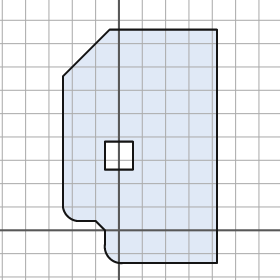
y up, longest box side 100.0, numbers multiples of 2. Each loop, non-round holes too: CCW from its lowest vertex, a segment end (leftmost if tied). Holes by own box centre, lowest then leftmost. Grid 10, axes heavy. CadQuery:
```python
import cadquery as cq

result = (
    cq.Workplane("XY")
    .moveTo(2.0, -14.0)
    .lineTo(42.0, -14.0)
    .lineTo(42.0, 86.0)
    .lineTo(-4.0, 86.0)
    .lineTo(-24.0, 66.0)
    .lineTo(-24.0, 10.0)
    .threePointArc((-22.0, 6.0), (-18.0, 4.0))
    .lineTo(-10.0, 4.0)
    .lineTo(-6.0, 0.0)
    .lineTo(-6.0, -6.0)
    .threePointArc((-4.0, -12.0), (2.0, -14.0))
    .close()
    .moveTo(-6.0, 26.0)
    .lineTo(6.0, 26.0)
    .lineTo(6.0, 38.0)
    .lineTo(-6.0, 38.0)
    .close()
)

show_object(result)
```